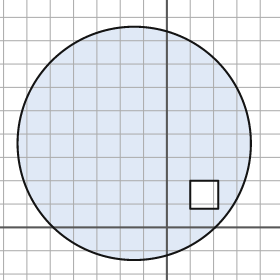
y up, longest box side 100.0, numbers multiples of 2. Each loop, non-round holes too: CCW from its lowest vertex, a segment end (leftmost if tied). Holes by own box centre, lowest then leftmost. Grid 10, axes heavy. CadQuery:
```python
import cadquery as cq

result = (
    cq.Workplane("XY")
    .moveTo(-14.0, 36.0)
    .circle(50.0)
    .moveTo(10.0, 8.0)
    .lineTo(22.0, 8.0)
    .lineTo(22.0, 20.0)
    .lineTo(10.0, 20.0)
    .close()
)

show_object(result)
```